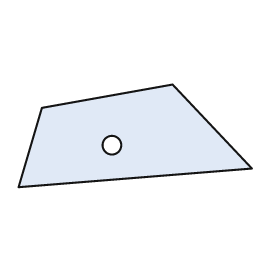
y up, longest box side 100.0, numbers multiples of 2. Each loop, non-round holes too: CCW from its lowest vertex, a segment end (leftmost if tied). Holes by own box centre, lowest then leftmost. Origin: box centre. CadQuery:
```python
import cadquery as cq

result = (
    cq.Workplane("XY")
    .moveTo(-50.0, -22.0)
    .lineTo(50.0, -14.0)
    .lineTo(16.0, 22.0)
    .lineTo(-40.0, 12.0)
    .close()
    .moveTo(-10.0, -4.0)
    .circle(4.0)
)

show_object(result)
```